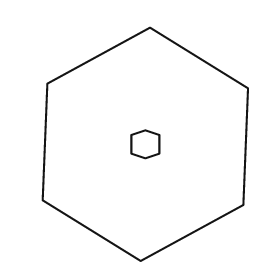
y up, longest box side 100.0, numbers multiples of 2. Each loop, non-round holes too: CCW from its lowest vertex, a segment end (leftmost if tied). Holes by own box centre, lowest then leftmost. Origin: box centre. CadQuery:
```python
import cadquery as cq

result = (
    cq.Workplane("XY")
    .moveTo(-2.0, -50.0)
    .lineTo(42.0, -26.0)
    .lineTo(44.0, 24.0)
    .lineTo(2.0, 50.0)
    .lineTo(-42.0, 26.0)
    .lineTo(-44.0, -24.0)
    .close()
    .moveTo(0.0, -6.0)
    .lineTo(6.0, -4.0)
    .lineTo(6.0, 4.0)
    .lineTo(0.0, 6.0)
    .lineTo(-6.0, 4.0)
    .lineTo(-6.0, -4.0)
    .close()
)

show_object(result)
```